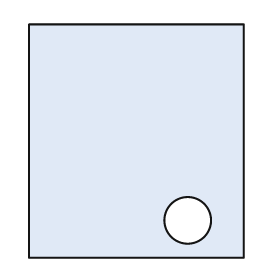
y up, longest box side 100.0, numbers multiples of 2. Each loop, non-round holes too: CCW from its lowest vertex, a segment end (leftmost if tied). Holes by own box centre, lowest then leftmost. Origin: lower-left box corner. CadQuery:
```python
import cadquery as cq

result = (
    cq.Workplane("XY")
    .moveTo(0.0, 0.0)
    .lineTo(92.0, 0.0)
    .lineTo(92.0, 100.0)
    .lineTo(0.0, 100.0)
    .close()
    .moveTo(68.0, 16.0)
    .circle(10.0)
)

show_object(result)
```